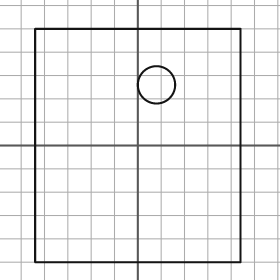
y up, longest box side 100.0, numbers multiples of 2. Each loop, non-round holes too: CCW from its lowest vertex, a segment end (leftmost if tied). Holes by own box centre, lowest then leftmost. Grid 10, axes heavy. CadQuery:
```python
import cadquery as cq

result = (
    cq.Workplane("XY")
    .moveTo(-44.0, -50.0)
    .lineTo(44.0, -50.0)
    .lineTo(44.0, 50.0)
    .lineTo(-44.0, 50.0)
    .close()
    .moveTo(8.0, 26.0)
    .circle(8.0)
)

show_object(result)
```